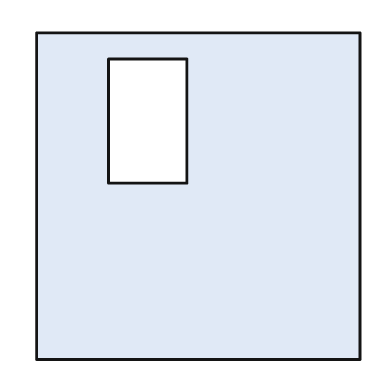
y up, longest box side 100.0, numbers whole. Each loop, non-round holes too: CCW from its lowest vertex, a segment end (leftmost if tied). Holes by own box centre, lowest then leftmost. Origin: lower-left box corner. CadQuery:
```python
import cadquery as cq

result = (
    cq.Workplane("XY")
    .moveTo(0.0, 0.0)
    .lineTo(99.0, 0.0)
    .lineTo(99.0, 100.0)
    .lineTo(0.0, 100.0)
    .close()
    .moveTo(22.0, 54.0)
    .lineTo(46.0, 54.0)
    .lineTo(46.0, 92.0)
    .lineTo(22.0, 92.0)
    .close()
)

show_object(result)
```